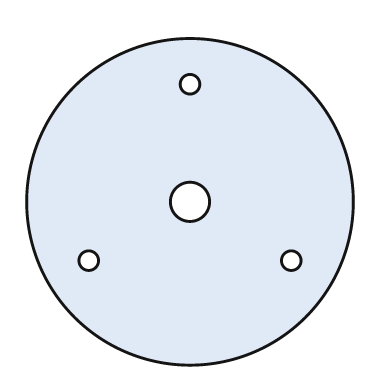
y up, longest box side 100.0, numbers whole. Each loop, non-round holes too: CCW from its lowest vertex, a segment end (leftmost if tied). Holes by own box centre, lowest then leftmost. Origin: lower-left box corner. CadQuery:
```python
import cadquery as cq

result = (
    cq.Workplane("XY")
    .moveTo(50.0, 50.0)
    .circle(50.0)
    .moveTo(19.0, 32.0)
    .circle(3.0)
    .moveTo(81.0, 32.0)
    .circle(3.0)
    .moveTo(50.0, 50.0)
    .circle(6.0)
    .moveTo(50.0, 86.0)
    .circle(3.0)
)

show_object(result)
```